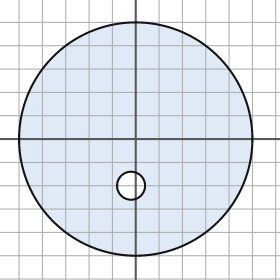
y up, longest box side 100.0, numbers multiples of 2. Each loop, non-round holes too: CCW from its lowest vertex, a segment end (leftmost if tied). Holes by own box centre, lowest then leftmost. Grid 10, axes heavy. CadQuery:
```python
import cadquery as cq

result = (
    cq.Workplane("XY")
    .moveTo(0.0, 0.0)
    .circle(50.0)
    .moveTo(-2.0, -20.0)
    .circle(6.0)
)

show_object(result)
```